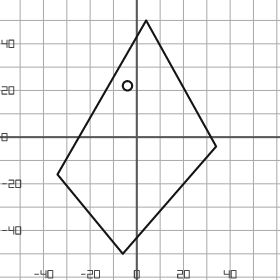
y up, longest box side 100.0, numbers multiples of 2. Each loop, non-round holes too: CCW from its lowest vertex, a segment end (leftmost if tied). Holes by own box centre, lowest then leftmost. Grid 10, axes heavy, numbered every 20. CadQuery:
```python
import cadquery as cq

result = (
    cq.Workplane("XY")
    .moveTo(-6.0, -50.0)
    .lineTo(34.0, -4.0)
    .lineTo(4.0, 50.0)
    .lineTo(-34.0, -16.0)
    .close()
    .moveTo(-4.0, 22.0)
    .circle(2.0)
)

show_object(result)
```